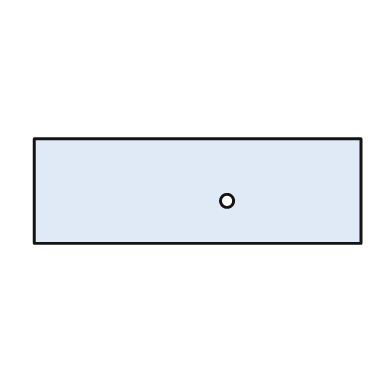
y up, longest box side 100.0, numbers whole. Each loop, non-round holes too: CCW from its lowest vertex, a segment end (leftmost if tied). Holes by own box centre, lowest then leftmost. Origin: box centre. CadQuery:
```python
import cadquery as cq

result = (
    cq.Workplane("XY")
    .moveTo(-50.0, -16.0)
    .lineTo(50.0, -16.0)
    .lineTo(50.0, 16.0)
    .lineTo(-50.0, 16.0)
    .close()
    .moveTo(9.0, -3.0)
    .circle(2.0)
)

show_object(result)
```